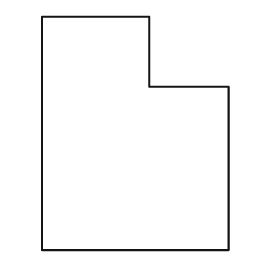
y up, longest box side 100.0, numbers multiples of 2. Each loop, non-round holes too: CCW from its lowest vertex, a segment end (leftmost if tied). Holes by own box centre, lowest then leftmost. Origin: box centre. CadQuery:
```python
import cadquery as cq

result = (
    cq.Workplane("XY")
    .moveTo(-40.0, -50.0)
    .lineTo(40.0, -50.0)
    .lineTo(40.0, 20.0)
    .lineTo(6.0, 20.0)
    .lineTo(6.0, 50.0)
    .lineTo(-40.0, 50.0)
    .close()
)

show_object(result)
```